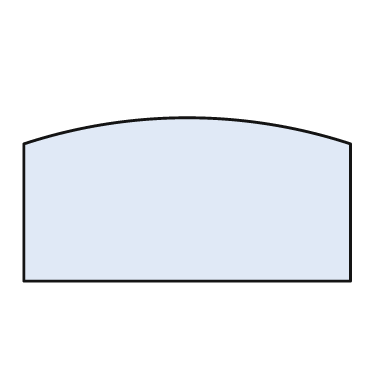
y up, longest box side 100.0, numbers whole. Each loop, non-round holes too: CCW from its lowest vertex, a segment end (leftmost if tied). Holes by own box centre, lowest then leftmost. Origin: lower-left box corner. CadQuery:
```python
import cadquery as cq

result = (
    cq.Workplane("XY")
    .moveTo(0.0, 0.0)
    .lineTo(100.0, 0.0)
    .lineTo(100.0, 42.0)
    .threePointArc((50.0, 50.0), (0.0, 42.0))
    .close()
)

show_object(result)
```